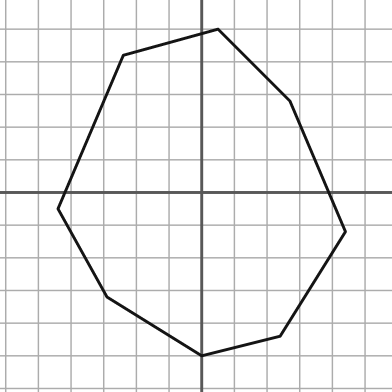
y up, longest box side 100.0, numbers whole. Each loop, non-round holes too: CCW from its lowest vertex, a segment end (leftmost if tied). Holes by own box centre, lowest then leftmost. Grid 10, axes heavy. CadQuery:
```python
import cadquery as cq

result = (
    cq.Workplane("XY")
    .moveTo(0.0, -50.0)
    .lineTo(24.0, -44.0)
    .lineTo(44.0, -12.0)
    .lineTo(27.0, 28.0)
    .lineTo(5.0, 50.0)
    .lineTo(-24.0, 42.0)
    .lineTo(-44.0, -5.0)
    .lineTo(-29.0, -32.0)
    .close()
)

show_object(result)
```